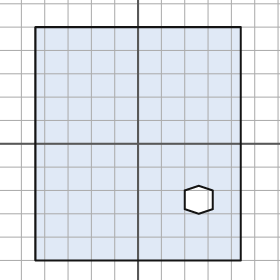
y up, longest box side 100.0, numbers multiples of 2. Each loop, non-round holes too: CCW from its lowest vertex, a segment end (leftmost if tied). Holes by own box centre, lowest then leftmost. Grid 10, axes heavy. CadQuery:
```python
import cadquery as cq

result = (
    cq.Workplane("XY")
    .moveTo(-44.0, -50.0)
    .lineTo(44.0, -50.0)
    .lineTo(44.0, 50.0)
    .lineTo(-44.0, 50.0)
    .close()
    .moveTo(26.0, -30.0)
    .lineTo(32.0, -28.0)
    .lineTo(32.0, -20.0)
    .lineTo(26.0, -18.0)
    .lineTo(20.0, -20.0)
    .lineTo(20.0, -28.0)
    .close()
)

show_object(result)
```